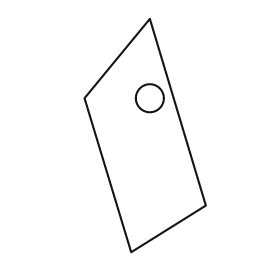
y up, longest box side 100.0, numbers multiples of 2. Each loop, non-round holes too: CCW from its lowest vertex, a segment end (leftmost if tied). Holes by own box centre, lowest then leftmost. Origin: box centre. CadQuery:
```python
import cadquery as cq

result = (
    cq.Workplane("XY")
    .moveTo(-6.0, -50.0)
    .lineTo(26.0, -30.0)
    .lineTo(2.0, 50.0)
    .lineTo(-26.0, 16.0)
    .close()
    .moveTo(2.0, 16.0)
    .circle(6.0)
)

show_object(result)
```